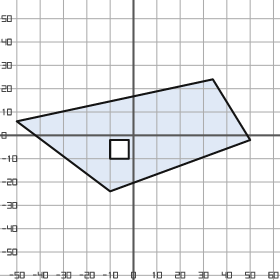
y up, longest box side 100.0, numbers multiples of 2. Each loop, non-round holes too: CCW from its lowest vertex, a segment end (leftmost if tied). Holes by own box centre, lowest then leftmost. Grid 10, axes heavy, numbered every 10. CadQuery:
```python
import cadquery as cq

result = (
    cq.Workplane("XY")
    .moveTo(-10.0, -24.0)
    .lineTo(50.0, -2.0)
    .lineTo(34.0, 24.0)
    .lineTo(-50.0, 6.0)
    .close()
    .moveTo(-10.0, -10.0)
    .lineTo(-2.0, -10.0)
    .lineTo(-2.0, -2.0)
    .lineTo(-10.0, -2.0)
    .close()
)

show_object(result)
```